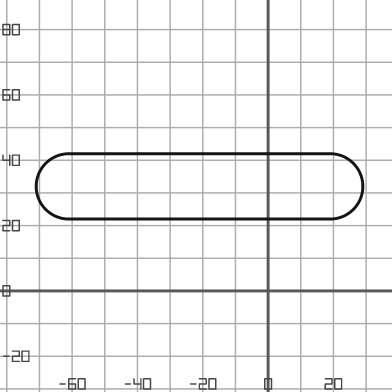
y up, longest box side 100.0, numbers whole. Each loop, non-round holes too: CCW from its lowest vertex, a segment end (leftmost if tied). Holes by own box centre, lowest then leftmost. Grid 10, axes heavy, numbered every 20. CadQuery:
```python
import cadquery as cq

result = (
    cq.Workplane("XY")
    .moveTo(-61.0, 22.0)
    .lineTo(19.0, 22.0)
    .threePointArc((29.0, 32.0), (19.0, 42.0))
    .lineTo(-61.0, 42.0)
    .threePointArc((-71.0, 32.0), (-61.0, 22.0))
    .close()
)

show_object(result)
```